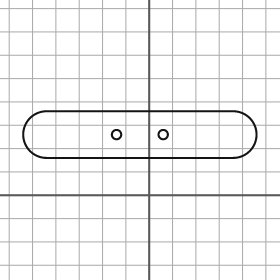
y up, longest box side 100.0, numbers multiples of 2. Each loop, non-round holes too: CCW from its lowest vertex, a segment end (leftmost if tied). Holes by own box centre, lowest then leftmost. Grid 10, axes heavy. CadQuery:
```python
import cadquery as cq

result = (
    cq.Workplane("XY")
    .moveTo(-44.0, 16.0)
    .lineTo(36.0, 16.0)
    .threePointArc((46.0, 26.0), (36.0, 36.0))
    .lineTo(-44.0, 36.0)
    .threePointArc((-54.0, 26.0), (-44.0, 16.0))
    .close()
    .moveTo(-14.0, 26.0)
    .circle(2.0)
    .moveTo(6.0, 26.0)
    .circle(2.0)
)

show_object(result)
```